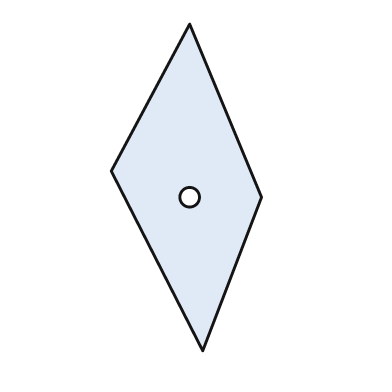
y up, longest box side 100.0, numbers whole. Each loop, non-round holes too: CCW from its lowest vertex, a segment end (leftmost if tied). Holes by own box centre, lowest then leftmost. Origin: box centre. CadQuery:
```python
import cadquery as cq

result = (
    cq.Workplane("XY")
    .moveTo(5.0, -50.0)
    .lineTo(23.0, -3.0)
    .lineTo(1.0, 50.0)
    .lineTo(-23.0, 5.0)
    .close()
    .moveTo(1.0, -3.0)
    .circle(3.0)
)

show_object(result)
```